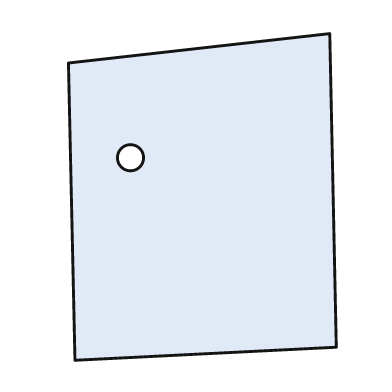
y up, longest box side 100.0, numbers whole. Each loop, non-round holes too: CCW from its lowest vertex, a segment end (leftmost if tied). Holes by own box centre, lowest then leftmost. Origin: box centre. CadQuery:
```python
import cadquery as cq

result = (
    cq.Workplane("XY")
    .moveTo(-39.0, -50.0)
    .lineTo(41.0, -46.0)
    .lineTo(39.0, 50.0)
    .lineTo(-41.0, 41.0)
    .close()
    .moveTo(-22.0, 12.0)
    .circle(4.0)
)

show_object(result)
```